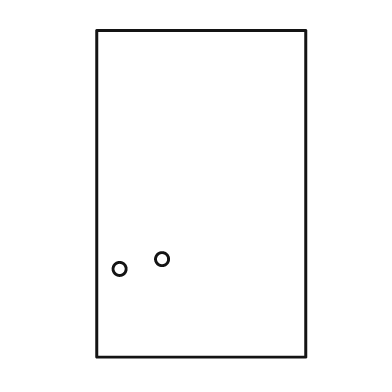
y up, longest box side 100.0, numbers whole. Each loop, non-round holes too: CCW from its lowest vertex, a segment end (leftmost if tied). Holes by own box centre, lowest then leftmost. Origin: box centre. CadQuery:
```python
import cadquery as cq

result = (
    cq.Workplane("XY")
    .moveTo(-32.0, -50.0)
    .lineTo(32.0, -50.0)
    .lineTo(32.0, 50.0)
    .lineTo(-32.0, 50.0)
    .close()
    .moveTo(-25.0, -23.0)
    .circle(2.0)
    .moveTo(-12.0, -20.0)
    .circle(2.0)
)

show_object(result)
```